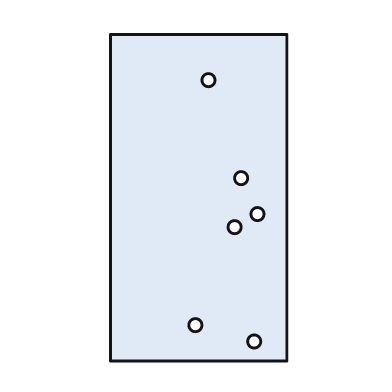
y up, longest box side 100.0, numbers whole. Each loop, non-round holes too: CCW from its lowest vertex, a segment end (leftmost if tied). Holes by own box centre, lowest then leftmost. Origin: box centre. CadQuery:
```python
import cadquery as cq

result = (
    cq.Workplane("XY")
    .moveTo(-27.0, -50.0)
    .lineTo(27.0, -50.0)
    .lineTo(27.0, 50.0)
    .lineTo(-27.0, 50.0)
    .close()
    .moveTo(17.0, -44.0)
    .circle(2.0)
    .moveTo(-1.0, -39.0)
    .circle(2.0)
    .moveTo(11.0, -9.0)
    .circle(2.0)
    .moveTo(18.0, -5.0)
    .circle(2.0)
    .moveTo(13.0, 6.0)
    .circle(2.0)
    .moveTo(3.0, 36.0)
    .circle(2.0)
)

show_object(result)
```